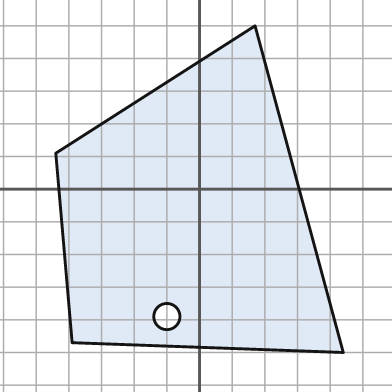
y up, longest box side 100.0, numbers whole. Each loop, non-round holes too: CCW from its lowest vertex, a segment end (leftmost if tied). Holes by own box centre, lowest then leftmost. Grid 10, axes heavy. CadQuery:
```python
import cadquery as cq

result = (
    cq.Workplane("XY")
    .moveTo(44.0, -50.0)
    .lineTo(17.0, 50.0)
    .lineTo(-44.0, 11.0)
    .lineTo(-39.0, -47.0)
    .close()
    .moveTo(-10.0, -39.0)
    .circle(4.0)
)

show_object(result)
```